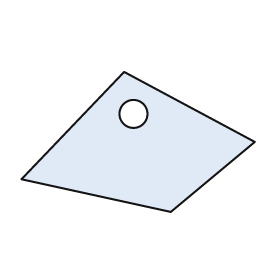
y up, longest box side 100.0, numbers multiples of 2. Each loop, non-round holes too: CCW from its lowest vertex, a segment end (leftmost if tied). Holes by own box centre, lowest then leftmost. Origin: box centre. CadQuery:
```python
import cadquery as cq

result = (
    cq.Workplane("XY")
    .moveTo(14.0, -30.0)
    .lineTo(50.0, 0.0)
    .lineTo(-6.0, 30.0)
    .lineTo(-50.0, -16.0)
    .close()
    .moveTo(-2.0, 12.0)
    .circle(6.0)
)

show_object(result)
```